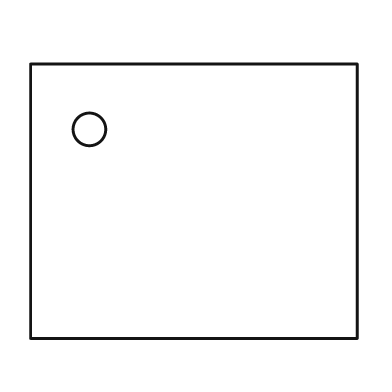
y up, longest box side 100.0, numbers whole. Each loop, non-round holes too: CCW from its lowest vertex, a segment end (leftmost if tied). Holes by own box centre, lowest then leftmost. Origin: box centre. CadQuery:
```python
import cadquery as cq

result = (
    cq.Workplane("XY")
    .moveTo(-50.0, -42.0)
    .lineTo(50.0, -42.0)
    .lineTo(50.0, 42.0)
    .lineTo(-50.0, 42.0)
    .close()
    .moveTo(-32.0, 22.0)
    .circle(5.0)
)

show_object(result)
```